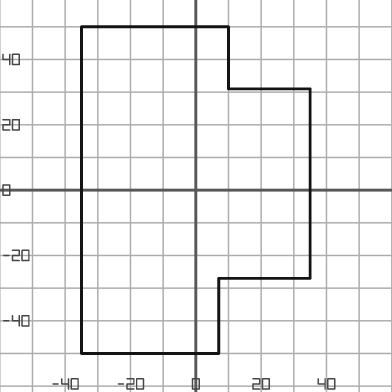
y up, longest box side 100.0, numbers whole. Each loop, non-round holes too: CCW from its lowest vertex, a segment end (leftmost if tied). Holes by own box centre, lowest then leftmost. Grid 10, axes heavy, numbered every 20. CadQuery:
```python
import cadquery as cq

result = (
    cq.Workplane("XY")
    .moveTo(-35.0, -50.0)
    .lineTo(7.0, -50.0)
    .lineTo(7.0, -27.0)
    .lineTo(35.0, -27.0)
    .lineTo(35.0, 31.0)
    .lineTo(10.0, 31.0)
    .lineTo(10.0, 50.0)
    .lineTo(-35.0, 50.0)
    .close()
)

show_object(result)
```